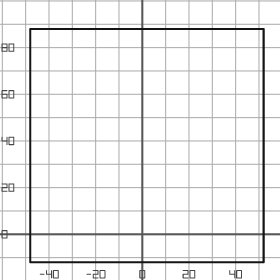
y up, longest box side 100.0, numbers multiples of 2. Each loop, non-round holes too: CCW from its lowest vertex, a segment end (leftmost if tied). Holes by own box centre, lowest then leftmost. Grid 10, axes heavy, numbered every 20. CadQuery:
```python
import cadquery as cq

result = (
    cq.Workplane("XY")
    .moveTo(-48.0, -12.0)
    .lineTo(52.0, -12.0)
    .lineTo(52.0, 88.0)
    .lineTo(-48.0, 88.0)
    .close()
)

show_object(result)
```